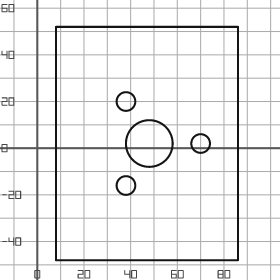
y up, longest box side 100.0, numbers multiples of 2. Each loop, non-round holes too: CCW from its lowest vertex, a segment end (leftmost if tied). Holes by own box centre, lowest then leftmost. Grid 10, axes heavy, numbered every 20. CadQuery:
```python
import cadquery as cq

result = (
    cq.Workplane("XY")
    .moveTo(8.0, -48.0)
    .lineTo(86.0, -48.0)
    .lineTo(86.0, 52.0)
    .lineTo(8.0, 52.0)
    .close()
    .moveTo(38.0, -16.0)
    .circle(4.0)
    .moveTo(48.0, 2.0)
    .circle(10.0)
    .moveTo(70.0, 2.0)
    .circle(4.0)
    .moveTo(38.0, 20.0)
    .circle(4.0)
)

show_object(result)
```